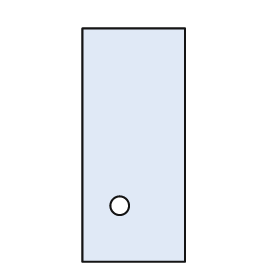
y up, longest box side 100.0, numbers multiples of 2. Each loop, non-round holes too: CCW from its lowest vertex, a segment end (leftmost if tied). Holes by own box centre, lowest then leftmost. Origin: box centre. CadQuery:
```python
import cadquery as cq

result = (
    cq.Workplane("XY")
    .moveTo(-22.0, -50.0)
    .lineTo(22.0, -50.0)
    .lineTo(22.0, 50.0)
    .lineTo(-22.0, 50.0)
    .close()
    .moveTo(-6.0, -26.0)
    .circle(4.0)
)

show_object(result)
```